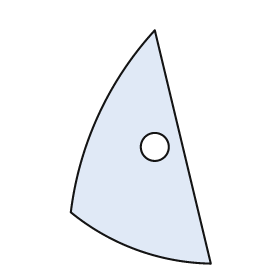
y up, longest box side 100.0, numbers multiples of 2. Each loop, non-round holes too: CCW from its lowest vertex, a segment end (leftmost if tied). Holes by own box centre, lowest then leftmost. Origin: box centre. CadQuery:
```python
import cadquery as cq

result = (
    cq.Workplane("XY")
    .moveTo(30.0, -50.0)
    .lineTo(6.0, 50.0)
    .threePointArc((-18.0, 14.0), (-30.0, -28.0))
    .threePointArc((-2.0, -44.0), (30.0, -50.0))
    .close()
    .moveTo(6.0, 0.0)
    .circle(6.0)
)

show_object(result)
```